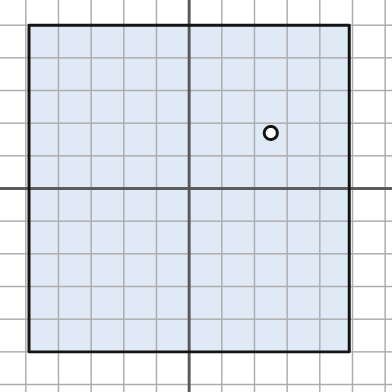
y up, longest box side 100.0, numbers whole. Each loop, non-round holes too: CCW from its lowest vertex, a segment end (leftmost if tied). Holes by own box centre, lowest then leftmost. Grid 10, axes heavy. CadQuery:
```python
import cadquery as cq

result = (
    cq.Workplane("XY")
    .moveTo(-49.0, -50.0)
    .lineTo(49.0, -50.0)
    .lineTo(49.0, 50.0)
    .lineTo(-49.0, 50.0)
    .close()
    .moveTo(25.0, 17.0)
    .circle(2.0)
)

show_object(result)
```